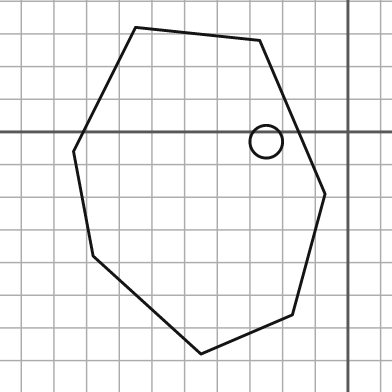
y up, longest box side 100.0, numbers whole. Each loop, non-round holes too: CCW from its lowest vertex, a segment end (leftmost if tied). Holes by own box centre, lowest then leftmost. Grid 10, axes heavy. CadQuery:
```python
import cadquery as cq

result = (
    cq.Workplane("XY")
    .moveTo(-45.0, -68.0)
    .lineTo(-17.0, -56.0)
    .lineTo(-7.0, -19.0)
    .lineTo(-27.0, 28.0)
    .lineTo(-65.0, 32.0)
    .lineTo(-84.0, -6.0)
    .lineTo(-78.0, -38.0)
    .close()
    .moveTo(-25.0, -3.0)
    .circle(5.0)
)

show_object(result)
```